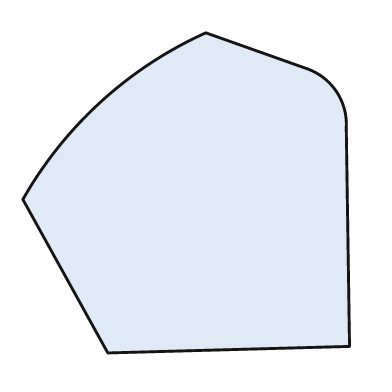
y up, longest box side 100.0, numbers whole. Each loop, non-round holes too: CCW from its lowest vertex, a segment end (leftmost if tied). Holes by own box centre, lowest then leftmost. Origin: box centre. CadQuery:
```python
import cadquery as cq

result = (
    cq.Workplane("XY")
    .moveTo(-24.0, -49.0)
    .lineTo(50.0, -47.0)
    .lineTo(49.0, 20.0)
    .threePointArc((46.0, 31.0), (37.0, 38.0))
    .lineTo(6.0, 49.0)
    .threePointArc((-26.0, 28.0), (-50.0, -2.0))
    .close()
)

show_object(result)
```